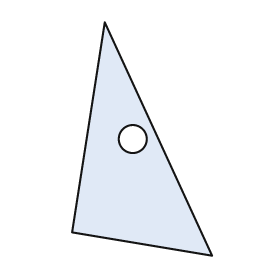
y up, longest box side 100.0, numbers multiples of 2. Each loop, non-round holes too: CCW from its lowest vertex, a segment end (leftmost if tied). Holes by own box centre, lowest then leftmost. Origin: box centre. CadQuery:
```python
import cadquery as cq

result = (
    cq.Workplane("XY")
    .moveTo(30.0, -50.0)
    .lineTo(-16.0, 50.0)
    .lineTo(-30.0, -40.0)
    .close()
    .moveTo(-4.0, 0.0)
    .circle(6.0)
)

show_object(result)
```